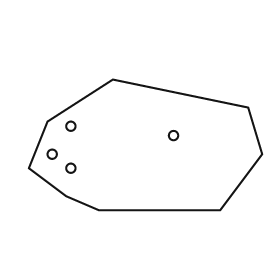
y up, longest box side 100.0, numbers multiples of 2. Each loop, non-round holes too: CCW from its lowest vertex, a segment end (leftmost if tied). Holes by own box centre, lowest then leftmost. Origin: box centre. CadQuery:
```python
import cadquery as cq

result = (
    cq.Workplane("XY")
    .moveTo(-20.0, -28.0)
    .lineTo(32.0, -28.0)
    .lineTo(50.0, -4.0)
    .lineTo(44.0, 16.0)
    .lineTo(-14.0, 28.0)
    .lineTo(-42.0, 10.0)
    .lineTo(-50.0, -10.0)
    .lineTo(-34.0, -22.0)
    .close()
    .moveTo(-32.0, -10.0)
    .circle(2.0)
    .moveTo(-40.0, -4.0)
    .circle(2.0)
    .moveTo(12.0, 4.0)
    .circle(2.0)
    .moveTo(-32.0, 8.0)
    .circle(2.0)
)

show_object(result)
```